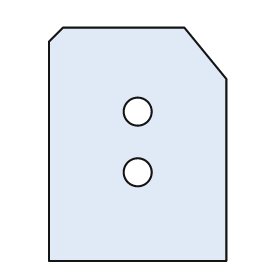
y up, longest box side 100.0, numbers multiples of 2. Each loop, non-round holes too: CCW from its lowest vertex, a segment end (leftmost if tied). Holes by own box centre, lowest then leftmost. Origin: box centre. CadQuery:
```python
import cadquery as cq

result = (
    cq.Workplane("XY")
    .moveTo(-38.0, -50.0)
    .lineTo(38.0, -50.0)
    .lineTo(38.0, 28.0)
    .lineTo(20.0, 50.0)
    .lineTo(-32.0, 50.0)
    .lineTo(-38.0, 44.0)
    .close()
    .moveTo(0.0, -12.0)
    .circle(6.0)
    .moveTo(0.0, 14.0)
    .circle(6.0)
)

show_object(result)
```